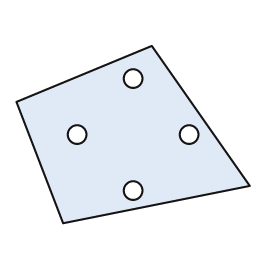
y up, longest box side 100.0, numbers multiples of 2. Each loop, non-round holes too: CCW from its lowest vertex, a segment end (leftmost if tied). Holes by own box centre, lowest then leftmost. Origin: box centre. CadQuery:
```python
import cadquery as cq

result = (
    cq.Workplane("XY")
    .moveTo(-30.0, -38.0)
    .lineTo(50.0, -22.0)
    .lineTo(8.0, 38.0)
    .lineTo(-50.0, 14.0)
    .close()
    .moveTo(0.0, -24.0)
    .circle(4.0)
    .moveTo(-24.0, 0.0)
    .circle(4.0)
    .moveTo(24.0, 0.0)
    .circle(4.0)
    .moveTo(0.0, 24.0)
    .circle(4.0)
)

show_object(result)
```